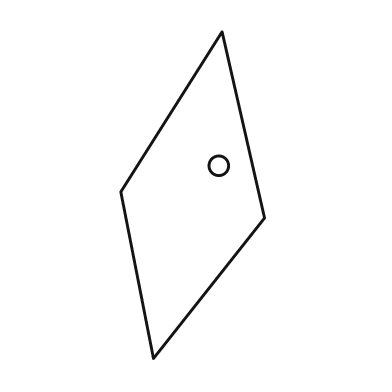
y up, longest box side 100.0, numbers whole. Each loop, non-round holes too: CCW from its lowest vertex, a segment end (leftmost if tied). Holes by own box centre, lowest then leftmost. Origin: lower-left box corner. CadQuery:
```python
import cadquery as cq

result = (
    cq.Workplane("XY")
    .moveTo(10.0, 0.0)
    .lineTo(44.0, 43.0)
    .lineTo(31.0, 100.0)
    .lineTo(0.0, 51.0)
    .close()
    .moveTo(30.0, 59.0)
    .circle(3.0)
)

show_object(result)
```